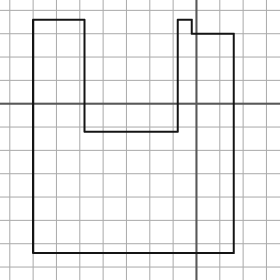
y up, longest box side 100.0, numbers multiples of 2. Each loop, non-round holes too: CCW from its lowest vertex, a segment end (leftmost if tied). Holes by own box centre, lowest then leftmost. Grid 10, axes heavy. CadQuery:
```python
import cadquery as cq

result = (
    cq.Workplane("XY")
    .moveTo(-70.0, -64.0)
    .lineTo(16.0, -64.0)
    .lineTo(16.0, 30.0)
    .lineTo(-2.0, 30.0)
    .lineTo(-2.0, 36.0)
    .lineTo(-8.0, 36.0)
    .lineTo(-8.0, -12.0)
    .lineTo(-48.0, -12.0)
    .lineTo(-48.0, 36.0)
    .lineTo(-70.0, 36.0)
    .close()
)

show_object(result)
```